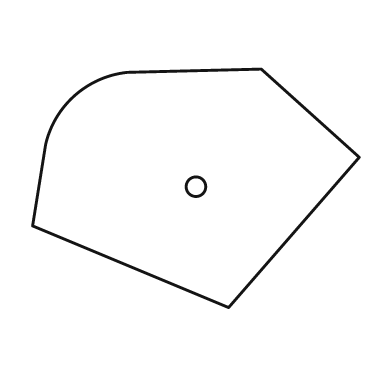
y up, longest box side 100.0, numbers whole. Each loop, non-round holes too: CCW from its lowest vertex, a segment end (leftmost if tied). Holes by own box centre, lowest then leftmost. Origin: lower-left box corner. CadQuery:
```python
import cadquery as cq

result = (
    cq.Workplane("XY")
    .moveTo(60.0, 0.0)
    .lineTo(100.0, 46.0)
    .lineTo(70.0, 73.0)
    .lineTo(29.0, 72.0)
    .threePointArc((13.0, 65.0), (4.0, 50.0))
    .lineTo(0.0, 25.0)
    .close()
    .moveTo(50.0, 37.0)
    .circle(3.0)
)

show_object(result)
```